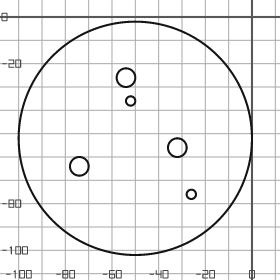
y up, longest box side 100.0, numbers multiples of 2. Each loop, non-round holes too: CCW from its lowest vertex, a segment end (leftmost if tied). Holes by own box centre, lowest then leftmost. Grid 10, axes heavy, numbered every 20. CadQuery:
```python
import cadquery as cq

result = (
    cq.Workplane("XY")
    .moveTo(-50.0, -52.0)
    .circle(50.0)
    .moveTo(-26.0, -76.0)
    .circle(2.0)
    .moveTo(-74.0, -64.0)
    .circle(4.0)
    .moveTo(-32.0, -56.0)
    .circle(4.0)
    .moveTo(-52.0, -36.0)
    .circle(2.0)
    .moveTo(-54.0, -26.0)
    .circle(4.0)
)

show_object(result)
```